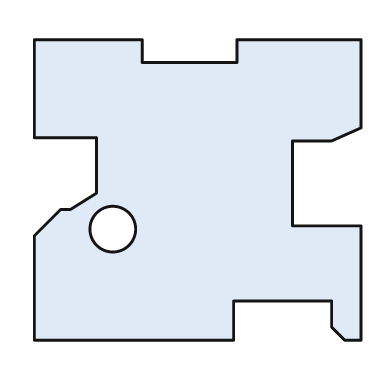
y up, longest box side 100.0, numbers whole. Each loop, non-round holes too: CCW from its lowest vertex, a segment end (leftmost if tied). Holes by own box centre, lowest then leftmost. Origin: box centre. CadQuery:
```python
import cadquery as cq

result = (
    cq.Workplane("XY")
    .moveTo(-50.0, -46.0)
    .lineTo(11.0, -46.0)
    .lineTo(11.0, -34.0)
    .lineTo(41.0, -34.0)
    .lineTo(41.0, -42.0)
    .lineTo(45.0, -46.0)
    .lineTo(50.0, -46.0)
    .lineTo(50.0, -11.0)
    .lineTo(29.0, -11.0)
    .lineTo(29.0, 15.0)
    .lineTo(41.0, 15.0)
    .lineTo(50.0, 19.0)
    .lineTo(50.0, 46.0)
    .lineTo(12.0, 46.0)
    .lineTo(12.0, 39.0)
    .lineTo(-17.0, 39.0)
    .lineTo(-17.0, 46.0)
    .lineTo(-50.0, 46.0)
    .lineTo(-50.0, 16.0)
    .lineTo(-31.0, 16.0)
    .lineTo(-31.0, -1.0)
    .lineTo(-39.0, -6.0)
    .lineTo(-42.0, -6.0)
    .lineTo(-50.0, -14.0)
    .close()
    .moveTo(-26.0, -12.0)
    .circle(7.0)
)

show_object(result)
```